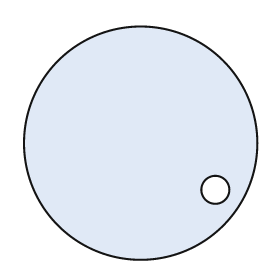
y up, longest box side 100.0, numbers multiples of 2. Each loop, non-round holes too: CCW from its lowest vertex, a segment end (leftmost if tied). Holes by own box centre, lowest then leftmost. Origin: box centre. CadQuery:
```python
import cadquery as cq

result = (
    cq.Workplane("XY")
    .moveTo(0.0, 0.0)
    .circle(50.0)
    .moveTo(32.0, -20.0)
    .circle(6.0)
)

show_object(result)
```